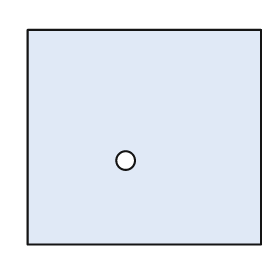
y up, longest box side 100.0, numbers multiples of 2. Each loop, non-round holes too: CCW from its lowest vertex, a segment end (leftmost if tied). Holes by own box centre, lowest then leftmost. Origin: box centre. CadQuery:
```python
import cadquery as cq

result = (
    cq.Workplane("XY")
    .moveTo(-50.0, -46.0)
    .lineTo(50.0, -46.0)
    .lineTo(50.0, 46.0)
    .lineTo(-50.0, 46.0)
    .close()
    .moveTo(-8.0, -10.0)
    .circle(4.0)
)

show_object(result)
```